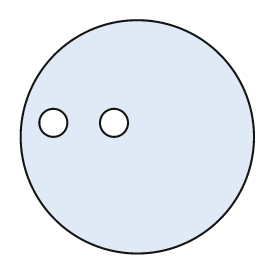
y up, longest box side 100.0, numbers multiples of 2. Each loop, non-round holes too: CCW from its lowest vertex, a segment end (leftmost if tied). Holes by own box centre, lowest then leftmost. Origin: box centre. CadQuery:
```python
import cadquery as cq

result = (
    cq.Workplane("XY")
    .moveTo(0.0, 0.0)
    .circle(50.0)
    .moveTo(-36.0, 6.0)
    .circle(6.0)
    .moveTo(-10.0, 6.0)
    .circle(6.0)
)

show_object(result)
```